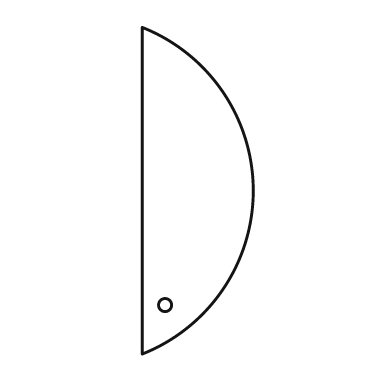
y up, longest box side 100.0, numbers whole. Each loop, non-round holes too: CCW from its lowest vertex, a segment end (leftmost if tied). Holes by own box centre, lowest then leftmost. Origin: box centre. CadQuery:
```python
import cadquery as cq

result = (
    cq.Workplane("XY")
    .moveTo(-17.0, -50.0)
    .threePointArc((17.0, 0.0), (-17.0, 50.0))
    .close()
    .moveTo(-10.0, -35.0)
    .circle(2.0)
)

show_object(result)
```